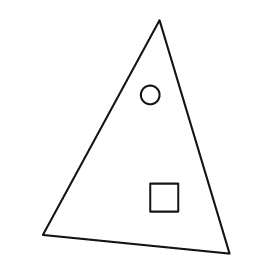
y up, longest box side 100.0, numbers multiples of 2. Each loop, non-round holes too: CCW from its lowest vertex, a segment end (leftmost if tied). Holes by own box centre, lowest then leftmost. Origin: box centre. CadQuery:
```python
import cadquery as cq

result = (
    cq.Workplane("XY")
    .moveTo(40.0, -50.0)
    .lineTo(10.0, 50.0)
    .lineTo(-40.0, -42.0)
    .close()
    .moveTo(6.0, -32.0)
    .lineTo(18.0, -32.0)
    .lineTo(18.0, -20.0)
    .lineTo(6.0, -20.0)
    .close()
    .moveTo(6.0, 18.0)
    .circle(4.0)
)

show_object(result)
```